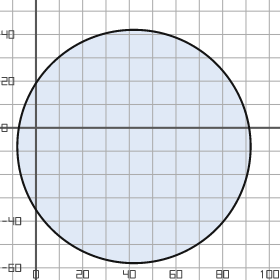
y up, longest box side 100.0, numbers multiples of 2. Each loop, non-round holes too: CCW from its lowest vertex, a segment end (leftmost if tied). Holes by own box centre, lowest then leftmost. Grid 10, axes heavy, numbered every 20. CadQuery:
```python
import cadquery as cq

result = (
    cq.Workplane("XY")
    .moveTo(42.0, -8.0)
    .circle(50.0)
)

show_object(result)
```